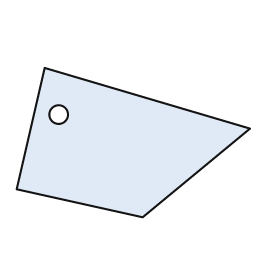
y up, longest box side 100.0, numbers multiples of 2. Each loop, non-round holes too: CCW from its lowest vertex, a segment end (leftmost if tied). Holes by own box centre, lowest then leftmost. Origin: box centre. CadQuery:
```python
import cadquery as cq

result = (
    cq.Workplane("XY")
    .moveTo(4.0, -32.0)
    .lineTo(50.0, 6.0)
    .lineTo(-38.0, 32.0)
    .lineTo(-50.0, -20.0)
    .close()
    .moveTo(-32.0, 12.0)
    .circle(4.0)
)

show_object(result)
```